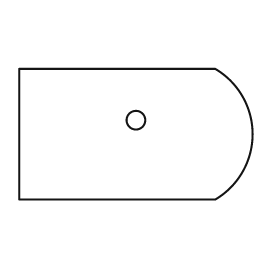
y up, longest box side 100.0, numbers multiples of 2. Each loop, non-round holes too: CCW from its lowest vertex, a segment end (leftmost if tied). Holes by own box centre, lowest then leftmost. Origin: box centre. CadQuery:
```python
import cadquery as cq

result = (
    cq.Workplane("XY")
    .moveTo(-50.0, -28.0)
    .lineTo(34.0, -28.0)
    .threePointArc((50.0, 0.0), (34.0, 28.0))
    .lineTo(-50.0, 28.0)
    .close()
    .moveTo(0.0, 6.0)
    .circle(4.0)
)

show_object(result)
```